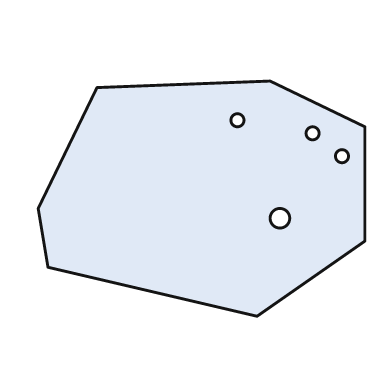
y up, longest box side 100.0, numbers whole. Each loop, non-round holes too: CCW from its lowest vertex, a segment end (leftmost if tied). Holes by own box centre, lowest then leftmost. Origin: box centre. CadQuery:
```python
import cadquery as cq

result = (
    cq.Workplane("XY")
    .moveTo(17.0, -36.0)
    .lineTo(50.0, -13.0)
    .lineTo(50.0, 22.0)
    .lineTo(21.0, 36.0)
    .lineTo(-32.0, 34.0)
    .lineTo(-50.0, -3.0)
    .lineTo(-47.0, -21.0)
    .close()
    .moveTo(24.0, -6.0)
    .circle(3.0)
    .moveTo(43.0, 13.0)
    .circle(2.0)
    .moveTo(34.0, 20.0)
    .circle(2.0)
    .moveTo(11.0, 24.0)
    .circle(2.0)
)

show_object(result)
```